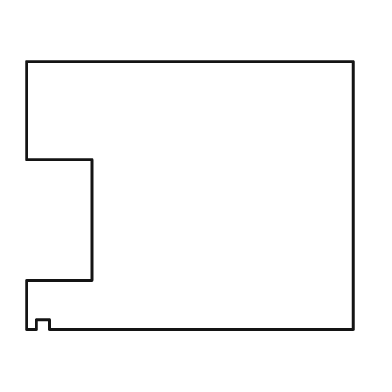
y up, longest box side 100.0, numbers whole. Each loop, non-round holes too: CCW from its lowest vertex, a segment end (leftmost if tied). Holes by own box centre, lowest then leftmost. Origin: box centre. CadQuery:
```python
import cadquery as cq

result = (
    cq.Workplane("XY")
    .moveTo(-50.0, -41.0)
    .lineTo(-47.0, -41.0)
    .lineTo(-47.0, -38.0)
    .lineTo(-43.0, -38.0)
    .lineTo(-43.0, -41.0)
    .lineTo(50.0, -41.0)
    .lineTo(50.0, 41.0)
    .lineTo(-50.0, 41.0)
    .lineTo(-50.0, 11.0)
    .lineTo(-30.0, 11.0)
    .lineTo(-30.0, -26.0)
    .lineTo(-50.0, -26.0)
    .close()
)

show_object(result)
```